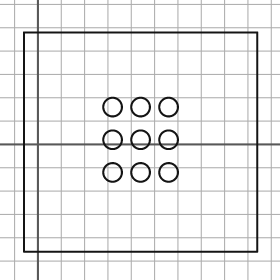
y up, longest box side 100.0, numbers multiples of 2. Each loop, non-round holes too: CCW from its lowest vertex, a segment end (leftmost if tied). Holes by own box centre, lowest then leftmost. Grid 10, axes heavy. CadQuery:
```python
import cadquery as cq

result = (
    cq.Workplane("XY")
    .moveTo(-6.0, -46.0)
    .lineTo(94.0, -46.0)
    .lineTo(94.0, 48.0)
    .lineTo(-6.0, 48.0)
    .close()
    .moveTo(32.0, -12.0)
    .circle(4.0)
    .moveTo(44.0, -12.0)
    .circle(4.0)
    .moveTo(56.0, -12.0)
    .circle(4.0)
    .moveTo(32.0, 2.0)
    .circle(4.0)
    .moveTo(44.0, 2.0)
    .circle(4.0)
    .moveTo(56.0, 2.0)
    .circle(4.0)
    .moveTo(32.0, 16.0)
    .circle(4.0)
    .moveTo(44.0, 16.0)
    .circle(4.0)
    .moveTo(56.0, 16.0)
    .circle(4.0)
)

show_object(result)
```